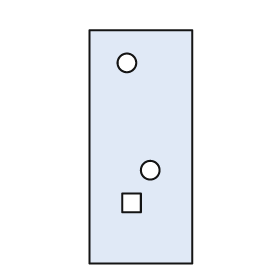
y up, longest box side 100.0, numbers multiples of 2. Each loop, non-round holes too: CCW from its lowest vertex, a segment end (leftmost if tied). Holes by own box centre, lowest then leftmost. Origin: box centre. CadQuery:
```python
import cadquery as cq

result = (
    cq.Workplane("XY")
    .moveTo(-22.0, -50.0)
    .lineTo(22.0, -50.0)
    .lineTo(22.0, 50.0)
    .lineTo(-22.0, 50.0)
    .close()
    .moveTo(-8.0, -28.0)
    .lineTo(0.0, -28.0)
    .lineTo(0.0, -20.0)
    .lineTo(-8.0, -20.0)
    .close()
    .moveTo(4.0, -10.0)
    .circle(4.0)
    .moveTo(-6.0, 36.0)
    .circle(4.0)
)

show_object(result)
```